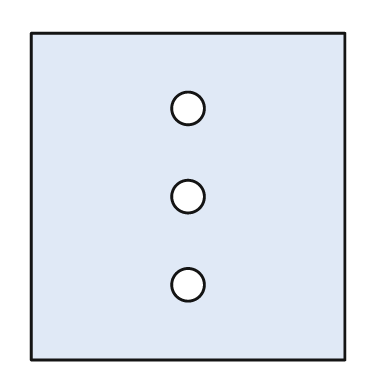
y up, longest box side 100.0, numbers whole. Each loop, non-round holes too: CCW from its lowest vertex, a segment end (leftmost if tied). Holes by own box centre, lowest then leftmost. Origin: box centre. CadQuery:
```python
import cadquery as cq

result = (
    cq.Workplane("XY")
    .moveTo(-48.0, -50.0)
    .lineTo(48.0, -50.0)
    .lineTo(48.0, 50.0)
    .lineTo(-48.0, 50.0)
    .close()
    .moveTo(0.0, -27.0)
    .circle(5.0)
    .moveTo(0.0, 0.0)
    .circle(5.0)
    .moveTo(0.0, 27.0)
    .circle(5.0)
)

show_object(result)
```